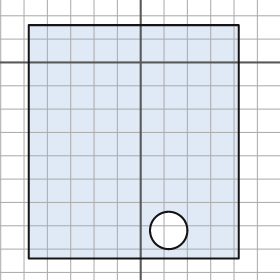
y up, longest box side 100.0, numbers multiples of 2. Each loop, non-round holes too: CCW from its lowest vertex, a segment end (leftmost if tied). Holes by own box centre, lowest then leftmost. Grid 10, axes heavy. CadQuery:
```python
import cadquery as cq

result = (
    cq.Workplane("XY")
    .moveTo(-48.0, -84.0)
    .lineTo(42.0, -84.0)
    .lineTo(42.0, 16.0)
    .lineTo(-48.0, 16.0)
    .close()
    .moveTo(12.0, -72.0)
    .circle(8.0)
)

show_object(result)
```